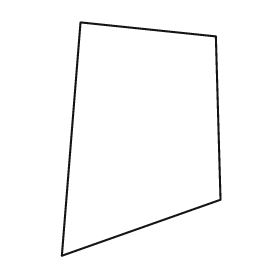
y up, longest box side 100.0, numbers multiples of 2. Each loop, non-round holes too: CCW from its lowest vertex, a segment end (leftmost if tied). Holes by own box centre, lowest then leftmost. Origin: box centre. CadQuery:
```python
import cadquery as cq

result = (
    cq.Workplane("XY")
    .moveTo(-34.0, -50.0)
    .lineTo(34.0, -26.0)
    .lineTo(32.0, 44.0)
    .lineTo(-26.0, 50.0)
    .close()
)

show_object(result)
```